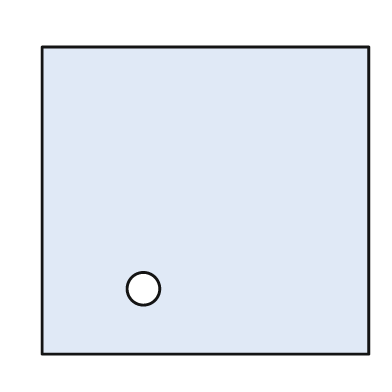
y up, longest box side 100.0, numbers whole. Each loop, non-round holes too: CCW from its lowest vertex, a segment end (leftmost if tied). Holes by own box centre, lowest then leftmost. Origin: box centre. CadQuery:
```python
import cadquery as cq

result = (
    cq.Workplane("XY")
    .moveTo(-50.0, -47.0)
    .lineTo(50.0, -47.0)
    .lineTo(50.0, 47.0)
    .lineTo(-50.0, 47.0)
    .close()
    .moveTo(-19.0, -27.0)
    .circle(5.0)
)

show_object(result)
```